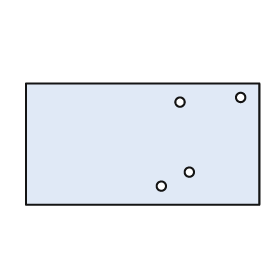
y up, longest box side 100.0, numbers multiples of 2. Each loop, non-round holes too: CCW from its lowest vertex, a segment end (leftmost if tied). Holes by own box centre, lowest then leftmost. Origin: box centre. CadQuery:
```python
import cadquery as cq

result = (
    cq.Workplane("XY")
    .moveTo(-50.0, -26.0)
    .lineTo(50.0, -26.0)
    .lineTo(50.0, 26.0)
    .lineTo(-50.0, 26.0)
    .close()
    .moveTo(8.0, -18.0)
    .circle(2.0)
    .moveTo(20.0, -12.0)
    .circle(2.0)
    .moveTo(16.0, 18.0)
    .circle(2.0)
    .moveTo(42.0, 20.0)
    .circle(2.0)
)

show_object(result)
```